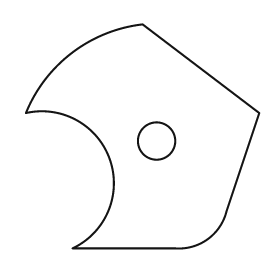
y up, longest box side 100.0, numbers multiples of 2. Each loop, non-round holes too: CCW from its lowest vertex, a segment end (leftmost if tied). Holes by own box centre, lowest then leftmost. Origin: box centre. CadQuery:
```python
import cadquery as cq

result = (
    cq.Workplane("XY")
    .moveTo(-30.0, -48.0)
    .lineTo(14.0, -48.0)
    .threePointArc((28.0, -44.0), (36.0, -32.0))
    .lineTo(50.0, 10.0)
    .lineTo(0.0, 48.0)
    .threePointArc((-30.0, 36.0), (-50.0, 10.0))
    .threePointArc((-14.0, -10.0), (-30.0, -48.0))
    .close()
    .moveTo(6.0, -2.0)
    .circle(8.0)
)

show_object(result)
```